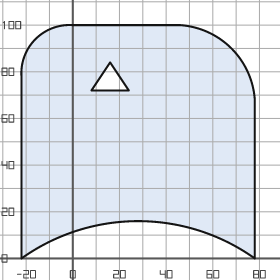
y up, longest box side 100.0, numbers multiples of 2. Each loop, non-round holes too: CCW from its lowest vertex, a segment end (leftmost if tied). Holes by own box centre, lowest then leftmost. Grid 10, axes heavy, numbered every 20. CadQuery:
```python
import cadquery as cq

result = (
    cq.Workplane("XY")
    .moveTo(-22.0, 0.0)
    .threePointArc((28.0, 16.0), (78.0, 0.0))
    .lineTo(78.0, 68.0)
    .threePointArc((68.0, 90.0), (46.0, 100.0))
    .lineTo(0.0, 100.0)
    .threePointArc((-16.0, 94.0), (-22.0, 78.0))
    .close()
    .moveTo(8.0, 72.0)
    .lineTo(24.0, 72.0)
    .lineTo(16.0, 84.0)
    .close()
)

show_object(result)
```